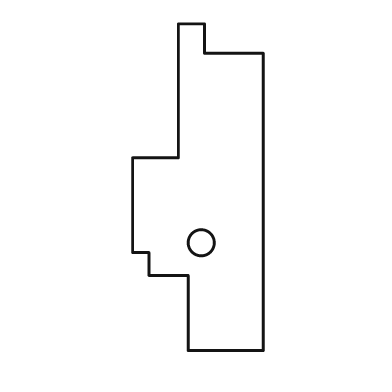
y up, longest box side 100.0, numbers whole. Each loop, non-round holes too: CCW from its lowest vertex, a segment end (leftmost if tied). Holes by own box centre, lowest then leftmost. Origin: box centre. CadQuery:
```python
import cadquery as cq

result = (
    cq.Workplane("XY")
    .moveTo(-3.0, -50.0)
    .lineTo(20.0, -50.0)
    .lineTo(20.0, 41.0)
    .lineTo(2.0, 41.0)
    .lineTo(2.0, 50.0)
    .lineTo(-6.0, 50.0)
    .lineTo(-6.0, 9.0)
    .lineTo(-20.0, 9.0)
    .lineTo(-20.0, -20.0)
    .lineTo(-15.0, -20.0)
    .lineTo(-15.0, -27.0)
    .lineTo(-3.0, -27.0)
    .close()
    .moveTo(1.0, -17.0)
    .circle(4.0)
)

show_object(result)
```